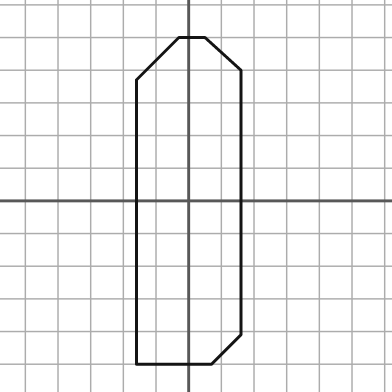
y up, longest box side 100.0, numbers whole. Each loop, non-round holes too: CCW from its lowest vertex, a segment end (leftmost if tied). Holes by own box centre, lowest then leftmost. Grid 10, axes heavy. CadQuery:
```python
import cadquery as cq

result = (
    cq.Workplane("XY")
    .moveTo(-16.0, -50.0)
    .lineTo(7.0, -50.0)
    .lineTo(16.0, -41.0)
    .lineTo(16.0, 40.0)
    .lineTo(5.0, 50.0)
    .lineTo(-3.0, 50.0)
    .lineTo(-16.0, 37.0)
    .close()
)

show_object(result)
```